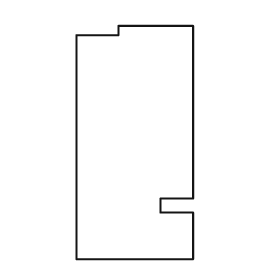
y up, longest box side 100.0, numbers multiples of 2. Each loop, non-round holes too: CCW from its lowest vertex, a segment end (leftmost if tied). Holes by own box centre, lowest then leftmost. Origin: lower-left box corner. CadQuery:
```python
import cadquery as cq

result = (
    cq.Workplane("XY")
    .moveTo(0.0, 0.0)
    .lineTo(50.0, 0.0)
    .lineTo(50.0, 20.0)
    .lineTo(36.0, 20.0)
    .lineTo(36.0, 26.0)
    .lineTo(50.0, 26.0)
    .lineTo(50.0, 100.0)
    .lineTo(18.0, 100.0)
    .lineTo(18.0, 96.0)
    .lineTo(0.0, 96.0)
    .close()
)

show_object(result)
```